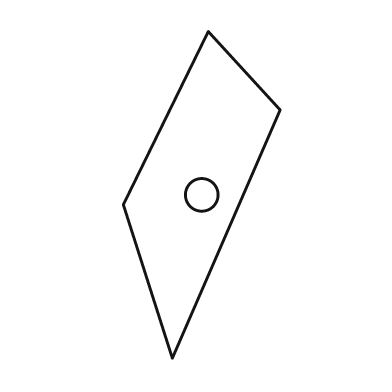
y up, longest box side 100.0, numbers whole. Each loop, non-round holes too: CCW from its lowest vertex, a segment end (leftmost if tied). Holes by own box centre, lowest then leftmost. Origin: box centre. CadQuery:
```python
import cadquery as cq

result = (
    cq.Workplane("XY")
    .moveTo(-9.0, -50.0)
    .lineTo(24.0, 26.0)
    .lineTo(2.0, 50.0)
    .lineTo(-24.0, -3.0)
    .close()
    .moveTo(0.0, 0.0)
    .circle(5.0)
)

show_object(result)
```